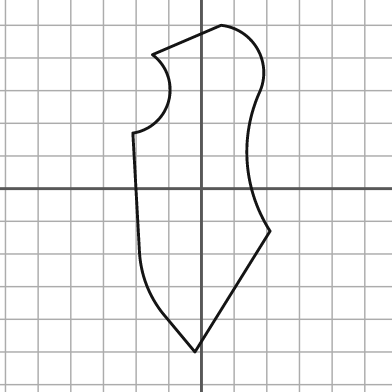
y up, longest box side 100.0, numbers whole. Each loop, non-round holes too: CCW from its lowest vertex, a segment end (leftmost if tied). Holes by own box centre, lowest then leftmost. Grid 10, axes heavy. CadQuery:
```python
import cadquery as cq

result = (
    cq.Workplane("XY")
    .moveTo(-2.0, -50.0)
    .lineTo(21.0, -13.0)
    .threePointArc((14.0, 8.0), (18.0, 30.0))
    .threePointArc((17.0, 43.0), (6.0, 50.0))
    .lineTo(-15.0, 41.0)
    .threePointArc((-10.0, 27.0), (-21.0, 17.0))
    .lineTo(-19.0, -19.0)
    .threePointArc((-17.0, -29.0), (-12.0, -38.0))
    .close()
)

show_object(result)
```